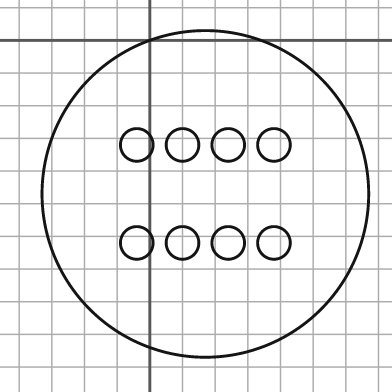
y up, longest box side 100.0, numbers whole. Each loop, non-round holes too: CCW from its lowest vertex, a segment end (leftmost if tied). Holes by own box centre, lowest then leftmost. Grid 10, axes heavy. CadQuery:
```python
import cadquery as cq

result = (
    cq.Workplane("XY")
    .moveTo(17.0, -47.0)
    .circle(50.0)
    .moveTo(-4.0, -62.0)
    .circle(5.0)
    .moveTo(10.0, -62.0)
    .circle(5.0)
    .moveTo(24.0, -62.0)
    .circle(5.0)
    .moveTo(38.0, -62.0)
    .circle(5.0)
    .moveTo(-4.0, -32.0)
    .circle(5.0)
    .moveTo(10.0, -32.0)
    .circle(5.0)
    .moveTo(24.0, -32.0)
    .circle(5.0)
    .moveTo(38.0, -32.0)
    .circle(5.0)
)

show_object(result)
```